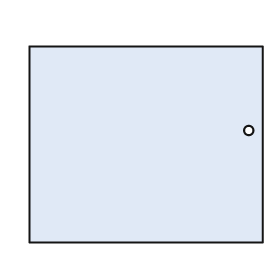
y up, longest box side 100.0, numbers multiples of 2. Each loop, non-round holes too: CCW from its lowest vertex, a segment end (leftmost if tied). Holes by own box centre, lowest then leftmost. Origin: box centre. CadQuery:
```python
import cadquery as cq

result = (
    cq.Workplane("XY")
    .moveTo(-50.0, -42.0)
    .lineTo(50.0, -42.0)
    .lineTo(50.0, 42.0)
    .lineTo(-50.0, 42.0)
    .close()
    .moveTo(44.0, 6.0)
    .circle(2.0)
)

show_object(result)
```